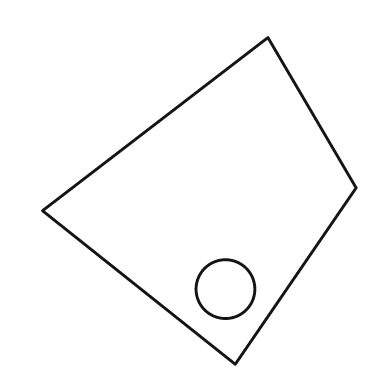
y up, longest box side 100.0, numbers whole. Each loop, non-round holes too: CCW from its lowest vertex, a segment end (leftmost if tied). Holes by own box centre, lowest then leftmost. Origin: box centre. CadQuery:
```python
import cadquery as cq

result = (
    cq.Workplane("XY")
    .moveTo(11.0, -50.0)
    .lineTo(48.0, 4.0)
    .lineTo(21.0, 50.0)
    .lineTo(-48.0, -3.0)
    .close()
    .moveTo(8.0, -27.0)
    .circle(9.0)
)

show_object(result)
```